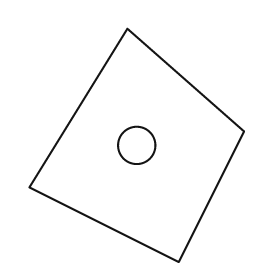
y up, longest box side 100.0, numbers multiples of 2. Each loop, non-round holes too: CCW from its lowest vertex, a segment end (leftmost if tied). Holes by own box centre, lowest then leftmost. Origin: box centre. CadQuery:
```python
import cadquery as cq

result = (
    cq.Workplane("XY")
    .moveTo(18.0, -50.0)
    .lineTo(46.0, 6.0)
    .lineTo(-4.0, 50.0)
    .lineTo(-46.0, -18.0)
    .close()
    .moveTo(0.0, 0.0)
    .circle(8.0)
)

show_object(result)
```